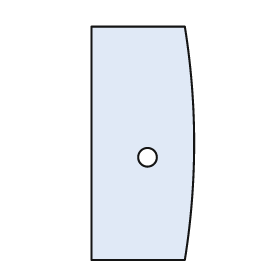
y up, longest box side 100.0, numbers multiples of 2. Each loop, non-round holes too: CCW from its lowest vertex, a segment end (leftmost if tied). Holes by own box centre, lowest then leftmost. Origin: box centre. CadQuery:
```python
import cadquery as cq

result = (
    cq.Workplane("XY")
    .moveTo(-22.0, -50.0)
    .lineTo(18.0, -50.0)
    .threePointArc((22.0, 0.0), (18.0, 50.0))
    .lineTo(-22.0, 50.0)
    .close()
    .moveTo(2.0, -6.0)
    .circle(4.0)
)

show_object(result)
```